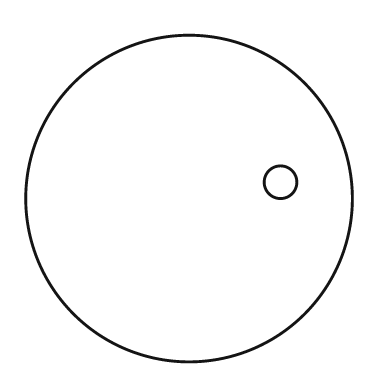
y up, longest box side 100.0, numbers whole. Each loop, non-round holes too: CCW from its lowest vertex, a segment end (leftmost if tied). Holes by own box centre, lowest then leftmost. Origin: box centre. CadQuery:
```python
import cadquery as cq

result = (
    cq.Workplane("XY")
    .moveTo(0.0, 0.0)
    .circle(50.0)
    .moveTo(28.0, 5.0)
    .circle(5.0)
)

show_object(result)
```